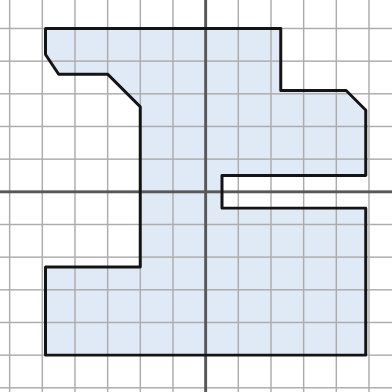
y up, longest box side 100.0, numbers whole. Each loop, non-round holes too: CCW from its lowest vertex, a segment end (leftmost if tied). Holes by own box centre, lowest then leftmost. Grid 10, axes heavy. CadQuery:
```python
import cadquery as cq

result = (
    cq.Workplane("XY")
    .moveTo(-49.0, -50.0)
    .lineTo(49.0, -50.0)
    .lineTo(49.0, -5.0)
    .lineTo(5.0, -5.0)
    .lineTo(5.0, 5.0)
    .lineTo(49.0, 5.0)
    .lineTo(49.0, 25.0)
    .lineTo(43.0, 31.0)
    .lineTo(23.0, 31.0)
    .lineTo(23.0, 50.0)
    .lineTo(-49.0, 50.0)
    .lineTo(-49.0, 42.0)
    .lineTo(-45.0, 36.0)
    .lineTo(-30.0, 36.0)
    .lineTo(-20.0, 26.0)
    .lineTo(-20.0, -23.0)
    .lineTo(-49.0, -23.0)
    .close()
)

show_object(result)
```